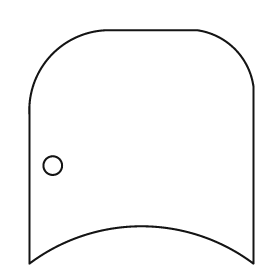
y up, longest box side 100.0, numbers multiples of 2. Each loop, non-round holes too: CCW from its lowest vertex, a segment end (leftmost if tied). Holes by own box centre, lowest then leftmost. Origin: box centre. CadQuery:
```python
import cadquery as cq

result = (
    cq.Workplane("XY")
    .moveTo(-48.0, -50.0)
    .threePointArc((0.0, -34.0), (48.0, -50.0))
    .lineTo(48.0, 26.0)
    .threePointArc((40.0, 42.0), (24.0, 50.0))
    .lineTo(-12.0, 50.0)
    .threePointArc((-38.0, 40.0), (-48.0, 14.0))
    .close()
    .moveTo(-38.0, -8.0)
    .circle(4.0)
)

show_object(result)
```